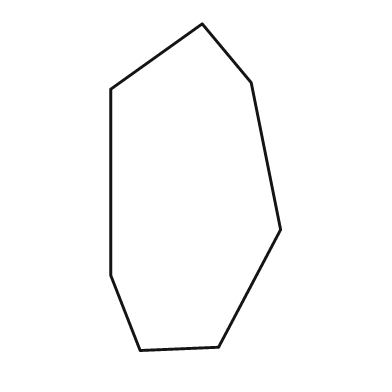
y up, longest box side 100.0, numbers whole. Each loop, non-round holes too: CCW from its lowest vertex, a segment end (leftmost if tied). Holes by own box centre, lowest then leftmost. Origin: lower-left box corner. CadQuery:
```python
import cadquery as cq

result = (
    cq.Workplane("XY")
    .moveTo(9.0, 0.0)
    .lineTo(33.0, 1.0)
    .lineTo(52.0, 37.0)
    .lineTo(43.0, 82.0)
    .lineTo(28.0, 100.0)
    .lineTo(0.0, 80.0)
    .lineTo(0.0, 23.0)
    .close()
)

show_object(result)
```